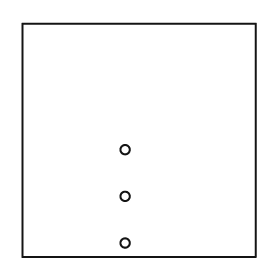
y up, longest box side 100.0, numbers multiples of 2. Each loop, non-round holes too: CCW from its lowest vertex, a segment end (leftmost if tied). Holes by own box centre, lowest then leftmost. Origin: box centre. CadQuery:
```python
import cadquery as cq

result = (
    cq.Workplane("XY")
    .moveTo(-50.0, -50.0)
    .lineTo(50.0, -50.0)
    .lineTo(50.0, 50.0)
    .lineTo(-50.0, 50.0)
    .close()
    .moveTo(-6.0, -44.0)
    .circle(2.0)
    .moveTo(-6.0, -24.0)
    .circle(2.0)
    .moveTo(-6.0, -4.0)
    .circle(2.0)
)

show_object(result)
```